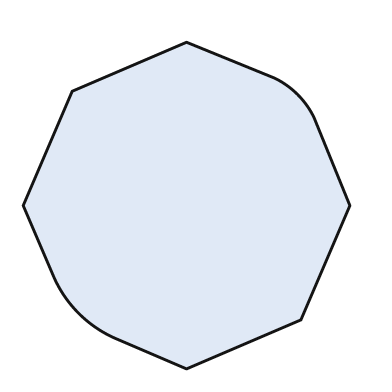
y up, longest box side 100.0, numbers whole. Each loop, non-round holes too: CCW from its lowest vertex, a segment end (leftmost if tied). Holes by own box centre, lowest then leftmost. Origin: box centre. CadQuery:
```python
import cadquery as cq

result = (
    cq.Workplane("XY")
    .moveTo(0.0, -50.0)
    .lineTo(35.0, -35.0)
    .lineTo(50.0, 0.0)
    .lineTo(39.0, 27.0)
    .threePointArc((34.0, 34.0), (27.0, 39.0))
    .lineTo(0.0, 50.0)
    .lineTo(-35.0, 35.0)
    .lineTo(-50.0, 0.0)
    .lineTo(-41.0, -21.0)
    .threePointArc((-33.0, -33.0), (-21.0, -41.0))
    .close()
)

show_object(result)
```